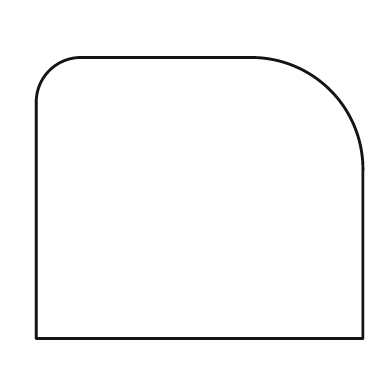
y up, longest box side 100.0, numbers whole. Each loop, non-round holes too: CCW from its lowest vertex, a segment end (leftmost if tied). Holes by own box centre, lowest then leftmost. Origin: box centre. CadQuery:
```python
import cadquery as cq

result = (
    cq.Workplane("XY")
    .moveTo(-50.0, -43.0)
    .lineTo(50.0, -43.0)
    .lineTo(50.0, 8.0)
    .threePointArc((40.0, 33.0), (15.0, 43.0))
    .lineTo(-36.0, 43.0)
    .threePointArc((-46.0, 39.0), (-50.0, 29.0))
    .close()
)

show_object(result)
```